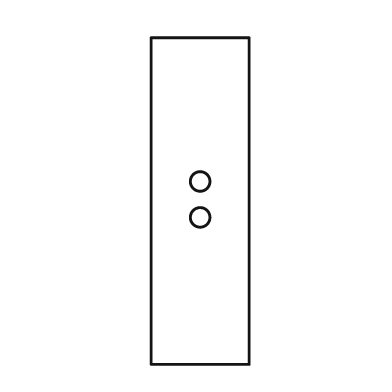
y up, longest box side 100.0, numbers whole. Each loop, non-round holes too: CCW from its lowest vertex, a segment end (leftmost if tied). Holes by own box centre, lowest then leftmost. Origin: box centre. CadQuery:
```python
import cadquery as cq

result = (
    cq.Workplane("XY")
    .moveTo(-15.0, -50.0)
    .lineTo(15.0, -50.0)
    .lineTo(15.0, 50.0)
    .lineTo(-15.0, 50.0)
    .close()
    .moveTo(0.0, -5.0)
    .circle(3.0)
    .moveTo(0.0, 6.0)
    .circle(3.0)
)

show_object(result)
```